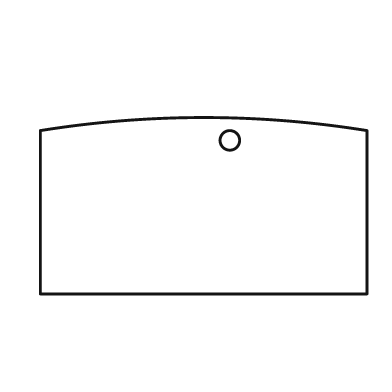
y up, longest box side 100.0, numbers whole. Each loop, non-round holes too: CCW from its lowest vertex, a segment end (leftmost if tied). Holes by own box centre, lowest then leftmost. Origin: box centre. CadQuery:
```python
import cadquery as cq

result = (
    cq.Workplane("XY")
    .moveTo(-50.0, -27.0)
    .lineTo(50.0, -27.0)
    .lineTo(50.0, 23.0)
    .threePointArc((0.0, 27.0), (-50.0, 23.0))
    .close()
    .moveTo(8.0, 20.0)
    .circle(3.0)
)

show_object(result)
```